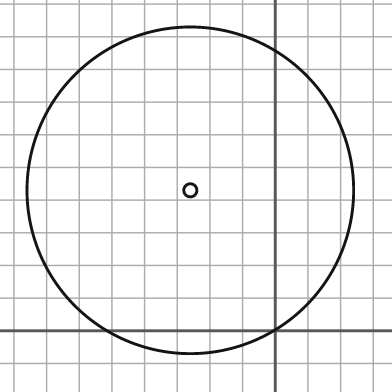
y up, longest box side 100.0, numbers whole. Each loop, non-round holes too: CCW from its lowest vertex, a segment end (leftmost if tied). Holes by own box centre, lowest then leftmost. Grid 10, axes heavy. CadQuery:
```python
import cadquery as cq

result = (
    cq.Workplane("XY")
    .moveTo(-26.0, 43.0)
    .circle(50.0)
    .moveTo(-26.0, 43.0)
    .circle(2.0)
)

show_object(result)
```